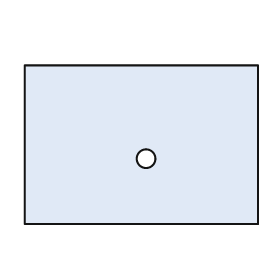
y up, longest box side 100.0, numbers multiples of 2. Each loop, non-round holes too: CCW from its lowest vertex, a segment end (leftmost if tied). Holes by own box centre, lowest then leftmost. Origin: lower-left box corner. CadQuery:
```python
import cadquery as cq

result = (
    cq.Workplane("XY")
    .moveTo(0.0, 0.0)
    .lineTo(100.0, 0.0)
    .lineTo(100.0, 68.0)
    .lineTo(0.0, 68.0)
    .close()
    .moveTo(52.0, 28.0)
    .circle(4.0)
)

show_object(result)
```